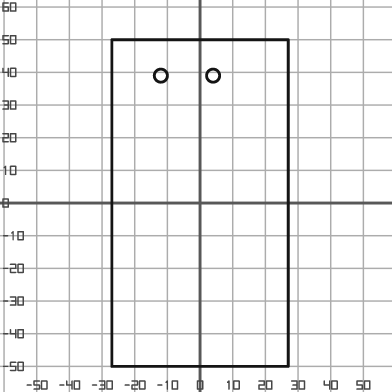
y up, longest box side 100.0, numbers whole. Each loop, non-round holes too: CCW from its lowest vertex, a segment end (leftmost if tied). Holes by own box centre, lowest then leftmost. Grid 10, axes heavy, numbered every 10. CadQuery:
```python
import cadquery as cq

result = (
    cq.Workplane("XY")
    .moveTo(-27.0, -50.0)
    .lineTo(27.0, -50.0)
    .lineTo(27.0, 50.0)
    .lineTo(-27.0, 50.0)
    .close()
    .moveTo(-12.0, 39.0)
    .circle(2.0)
    .moveTo(4.0, 39.0)
    .circle(2.0)
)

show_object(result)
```